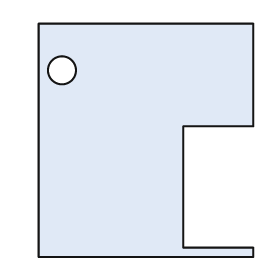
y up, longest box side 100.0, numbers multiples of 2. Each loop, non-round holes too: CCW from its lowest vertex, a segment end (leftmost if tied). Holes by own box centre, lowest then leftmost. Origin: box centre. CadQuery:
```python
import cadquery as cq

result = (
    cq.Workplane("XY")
    .moveTo(-46.0, -50.0)
    .lineTo(46.0, -50.0)
    .lineTo(46.0, -46.0)
    .lineTo(16.0, -46.0)
    .lineTo(16.0, 6.0)
    .lineTo(46.0, 6.0)
    .lineTo(46.0, 50.0)
    .lineTo(-46.0, 50.0)
    .close()
    .moveTo(-36.0, 30.0)
    .circle(6.0)
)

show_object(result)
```